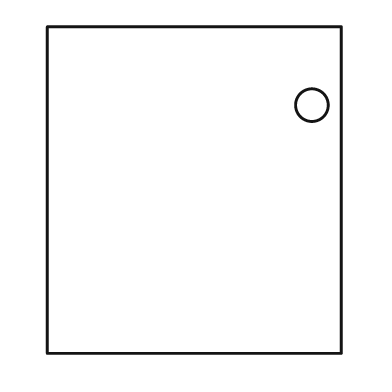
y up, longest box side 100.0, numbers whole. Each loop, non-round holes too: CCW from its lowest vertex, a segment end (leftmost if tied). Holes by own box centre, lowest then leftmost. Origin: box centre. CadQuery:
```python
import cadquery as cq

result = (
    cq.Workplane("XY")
    .moveTo(-45.0, -50.0)
    .lineTo(45.0, -50.0)
    .lineTo(45.0, 50.0)
    .lineTo(-45.0, 50.0)
    .close()
    .moveTo(36.0, 26.0)
    .circle(5.0)
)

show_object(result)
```